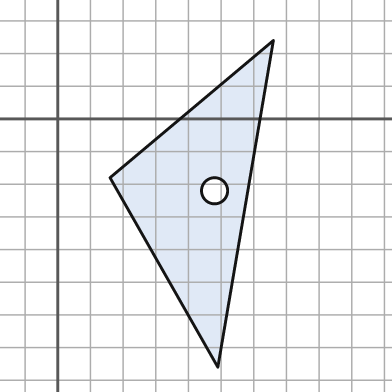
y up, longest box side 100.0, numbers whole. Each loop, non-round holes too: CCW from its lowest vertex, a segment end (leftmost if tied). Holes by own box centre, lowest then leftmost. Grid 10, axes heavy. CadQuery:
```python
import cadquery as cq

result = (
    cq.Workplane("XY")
    .moveTo(49.0, -76.0)
    .lineTo(66.0, 24.0)
    .lineTo(16.0, -18.0)
    .close()
    .moveTo(48.0, -22.0)
    .circle(4.0)
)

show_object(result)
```